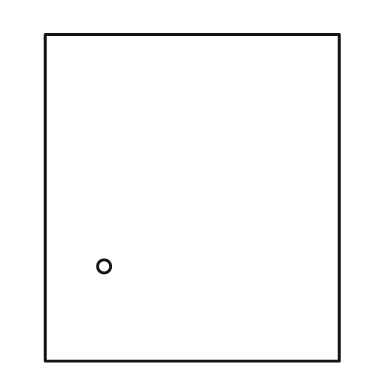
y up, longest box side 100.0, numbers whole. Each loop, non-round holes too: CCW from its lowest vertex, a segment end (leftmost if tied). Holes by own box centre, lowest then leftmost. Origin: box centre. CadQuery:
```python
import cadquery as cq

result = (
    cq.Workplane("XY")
    .moveTo(-45.0, -50.0)
    .lineTo(45.0, -50.0)
    .lineTo(45.0, 50.0)
    .lineTo(-45.0, 50.0)
    .close()
    .moveTo(-27.0, -21.0)
    .circle(2.0)
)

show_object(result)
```